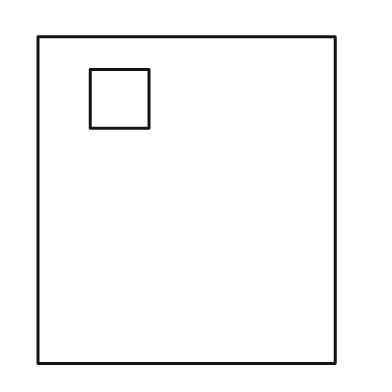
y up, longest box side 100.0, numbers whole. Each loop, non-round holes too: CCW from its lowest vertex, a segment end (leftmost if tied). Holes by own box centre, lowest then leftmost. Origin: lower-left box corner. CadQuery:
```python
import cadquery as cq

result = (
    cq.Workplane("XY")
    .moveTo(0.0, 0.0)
    .lineTo(91.0, 0.0)
    .lineTo(91.0, 100.0)
    .lineTo(0.0, 100.0)
    .close()
    .moveTo(16.0, 72.0)
    .lineTo(34.0, 72.0)
    .lineTo(34.0, 90.0)
    .lineTo(16.0, 90.0)
    .close()
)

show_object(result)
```